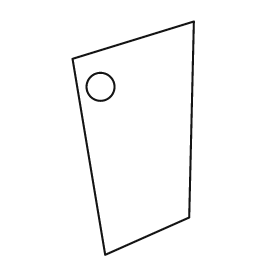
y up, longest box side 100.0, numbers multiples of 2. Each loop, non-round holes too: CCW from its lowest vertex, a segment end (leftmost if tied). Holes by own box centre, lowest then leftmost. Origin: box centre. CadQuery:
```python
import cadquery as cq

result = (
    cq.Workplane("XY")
    .moveTo(-12.0, -50.0)
    .lineTo(24.0, -34.0)
    .lineTo(26.0, 50.0)
    .lineTo(-26.0, 34.0)
    .close()
    .moveTo(-14.0, 22.0)
    .circle(6.0)
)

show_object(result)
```